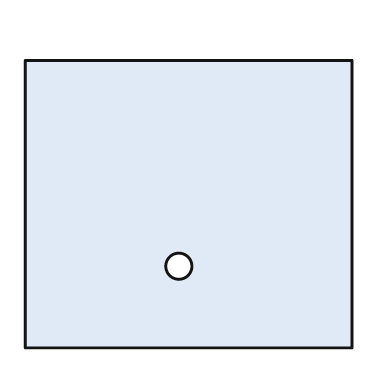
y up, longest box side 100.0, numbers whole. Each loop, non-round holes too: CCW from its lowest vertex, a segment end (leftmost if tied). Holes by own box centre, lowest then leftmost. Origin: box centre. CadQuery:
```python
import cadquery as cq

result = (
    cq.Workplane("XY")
    .moveTo(-50.0, -44.0)
    .lineTo(50.0, -44.0)
    .lineTo(50.0, 44.0)
    .lineTo(-50.0, 44.0)
    .close()
    .moveTo(-3.0, -19.0)
    .circle(4.0)
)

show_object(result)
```